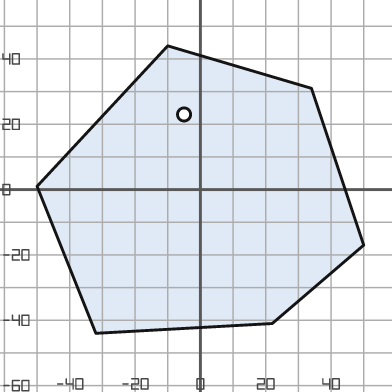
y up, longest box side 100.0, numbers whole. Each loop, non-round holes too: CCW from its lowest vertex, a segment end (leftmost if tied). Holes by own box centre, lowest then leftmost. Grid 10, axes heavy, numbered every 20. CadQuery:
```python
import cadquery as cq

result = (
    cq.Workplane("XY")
    .moveTo(-32.0, -44.0)
    .lineTo(22.0, -41.0)
    .lineTo(50.0, -17.0)
    .lineTo(34.0, 31.0)
    .lineTo(-10.0, 44.0)
    .lineTo(-50.0, 1.0)
    .close()
    .moveTo(-5.0, 23.0)
    .circle(2.0)
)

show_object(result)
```